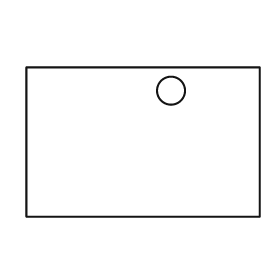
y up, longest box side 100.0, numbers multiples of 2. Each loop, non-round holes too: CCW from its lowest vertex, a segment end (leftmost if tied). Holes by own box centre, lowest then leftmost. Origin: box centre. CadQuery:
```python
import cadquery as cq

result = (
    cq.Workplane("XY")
    .moveTo(-50.0, -32.0)
    .lineTo(50.0, -32.0)
    .lineTo(50.0, 32.0)
    .lineTo(-50.0, 32.0)
    .close()
    .moveTo(12.0, 22.0)
    .circle(6.0)
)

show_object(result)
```